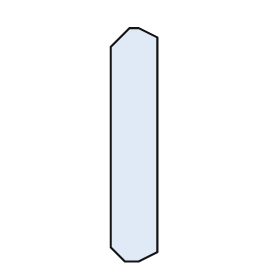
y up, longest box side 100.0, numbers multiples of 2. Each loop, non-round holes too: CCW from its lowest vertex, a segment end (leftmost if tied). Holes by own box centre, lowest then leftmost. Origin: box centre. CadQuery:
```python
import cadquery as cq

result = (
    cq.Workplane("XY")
    .moveTo(-4.0, -50.0)
    .lineTo(2.0, -50.0)
    .lineTo(10.0, -46.0)
    .lineTo(10.0, 46.0)
    .lineTo(2.0, 50.0)
    .lineTo(-2.0, 50.0)
    .lineTo(-10.0, 42.0)
    .lineTo(-10.0, -44.0)
    .close()
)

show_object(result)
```